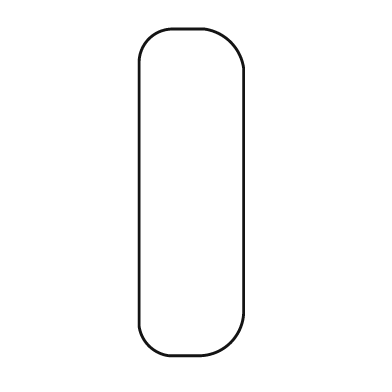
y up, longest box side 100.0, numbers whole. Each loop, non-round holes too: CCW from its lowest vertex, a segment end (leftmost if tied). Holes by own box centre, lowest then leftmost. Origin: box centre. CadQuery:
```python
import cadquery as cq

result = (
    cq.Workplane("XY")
    .moveTo(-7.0, -50.0)
    .lineTo(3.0, -50.0)
    .threePointArc((12.0, -46.0), (16.0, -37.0))
    .lineTo(16.0, 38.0)
    .threePointArc((12.0, 46.0), (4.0, 50.0))
    .lineTo(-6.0, 50.0)
    .threePointArc((-13.0, 47.0), (-16.0, 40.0))
    .lineTo(-16.0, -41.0)
    .threePointArc((-13.0, -47.0), (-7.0, -50.0))
    .close()
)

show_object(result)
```